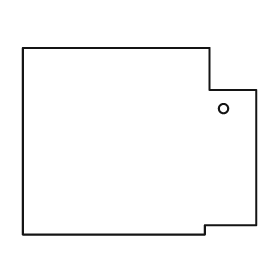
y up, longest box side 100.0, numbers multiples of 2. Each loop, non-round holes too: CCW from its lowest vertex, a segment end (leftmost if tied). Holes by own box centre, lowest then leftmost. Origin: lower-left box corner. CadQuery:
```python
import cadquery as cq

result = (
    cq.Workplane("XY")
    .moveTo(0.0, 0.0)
    .lineTo(78.0, 0.0)
    .lineTo(78.0, 4.0)
    .lineTo(100.0, 4.0)
    .lineTo(100.0, 62.0)
    .lineTo(80.0, 62.0)
    .lineTo(80.0, 80.0)
    .lineTo(0.0, 80.0)
    .close()
    .moveTo(86.0, 54.0)
    .circle(2.0)
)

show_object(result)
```